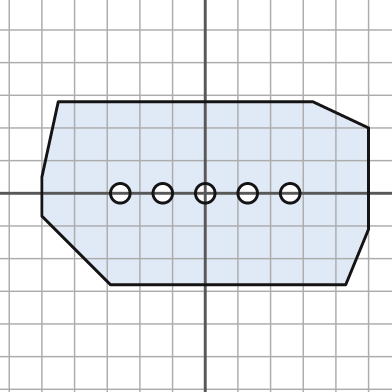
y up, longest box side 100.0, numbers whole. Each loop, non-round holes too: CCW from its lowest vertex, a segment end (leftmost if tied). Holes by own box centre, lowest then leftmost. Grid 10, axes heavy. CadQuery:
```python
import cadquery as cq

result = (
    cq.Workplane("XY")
    .moveTo(-29.0, -28.0)
    .lineTo(43.0, -28.0)
    .lineTo(50.0, -11.0)
    .lineTo(50.0, 20.0)
    .lineTo(33.0, 28.0)
    .lineTo(-45.0, 28.0)
    .lineTo(-50.0, 5.0)
    .lineTo(-50.0, -7.0)
    .close()
    .moveTo(-26.0, 0.0)
    .circle(3.0)
    .moveTo(-13.0, 0.0)
    .circle(3.0)
    .moveTo(0.0, 0.0)
    .circle(3.0)
    .moveTo(13.0, 0.0)
    .circle(3.0)
    .moveTo(26.0, 0.0)
    .circle(3.0)
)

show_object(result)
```